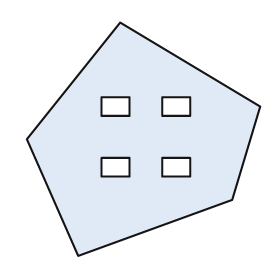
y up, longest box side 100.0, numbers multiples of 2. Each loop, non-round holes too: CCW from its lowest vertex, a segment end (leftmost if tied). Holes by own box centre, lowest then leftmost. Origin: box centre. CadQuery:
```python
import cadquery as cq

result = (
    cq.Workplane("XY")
    .moveTo(-28.0, -50.0)
    .lineTo(38.0, -26.0)
    .lineTo(50.0, 14.0)
    .lineTo(-10.0, 50.0)
    .lineTo(-50.0, 0.0)
    .close()
    .moveTo(-18.0, -16.0)
    .lineTo(-6.0, -16.0)
    .lineTo(-6.0, -8.0)
    .lineTo(-18.0, -8.0)
    .close()
    .moveTo(8.0, -16.0)
    .lineTo(20.0, -16.0)
    .lineTo(20.0, -8.0)
    .lineTo(8.0, -8.0)
    .close()
    .moveTo(-18.0, 10.0)
    .lineTo(-6.0, 10.0)
    .lineTo(-6.0, 18.0)
    .lineTo(-18.0, 18.0)
    .close()
    .moveTo(8.0, 10.0)
    .lineTo(20.0, 10.0)
    .lineTo(20.0, 18.0)
    .lineTo(8.0, 18.0)
    .close()
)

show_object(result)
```